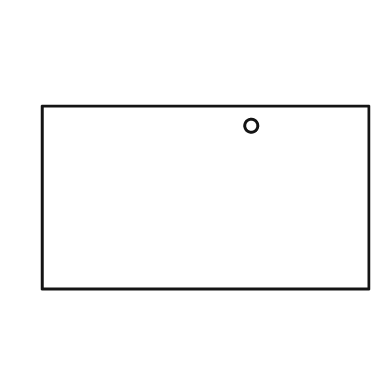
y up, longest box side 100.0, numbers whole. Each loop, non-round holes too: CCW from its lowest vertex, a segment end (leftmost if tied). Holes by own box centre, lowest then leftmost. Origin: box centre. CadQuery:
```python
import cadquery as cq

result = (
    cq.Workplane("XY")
    .moveTo(-50.0, -28.0)
    .lineTo(50.0, -28.0)
    .lineTo(50.0, 28.0)
    .lineTo(-50.0, 28.0)
    .close()
    .moveTo(14.0, 22.0)
    .circle(2.0)
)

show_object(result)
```